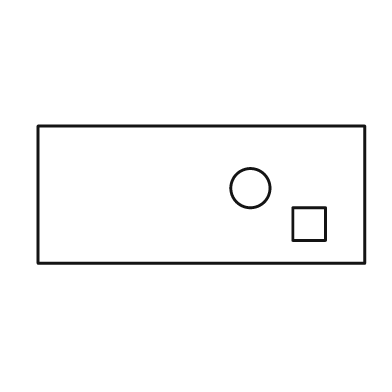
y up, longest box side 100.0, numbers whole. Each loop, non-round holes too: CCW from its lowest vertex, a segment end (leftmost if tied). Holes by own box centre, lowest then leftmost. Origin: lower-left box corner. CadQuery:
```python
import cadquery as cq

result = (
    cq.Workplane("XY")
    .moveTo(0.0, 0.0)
    .lineTo(100.0, 0.0)
    .lineTo(100.0, 42.0)
    .lineTo(0.0, 42.0)
    .close()
    .moveTo(78.0, 7.0)
    .lineTo(88.0, 7.0)
    .lineTo(88.0, 17.0)
    .lineTo(78.0, 17.0)
    .close()
    .moveTo(65.0, 23.0)
    .circle(6.0)
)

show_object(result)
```